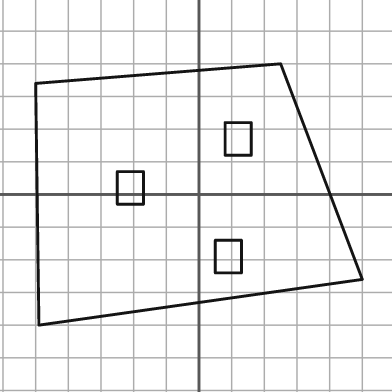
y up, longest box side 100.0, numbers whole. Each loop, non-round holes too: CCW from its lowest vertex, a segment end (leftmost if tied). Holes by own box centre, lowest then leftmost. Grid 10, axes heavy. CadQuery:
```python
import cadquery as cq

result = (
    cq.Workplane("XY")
    .moveTo(-49.0, -40.0)
    .lineTo(50.0, -26.0)
    .lineTo(25.0, 40.0)
    .lineTo(-50.0, 34.0)
    .close()
    .moveTo(5.0, -24.0)
    .lineTo(13.0, -24.0)
    .lineTo(13.0, -14.0)
    .lineTo(5.0, -14.0)
    .close()
    .moveTo(-25.0, -3.0)
    .lineTo(-17.0, -3.0)
    .lineTo(-17.0, 7.0)
    .lineTo(-25.0, 7.0)
    .close()
    .moveTo(8.0, 12.0)
    .lineTo(16.0, 12.0)
    .lineTo(16.0, 22.0)
    .lineTo(8.0, 22.0)
    .close()
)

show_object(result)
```